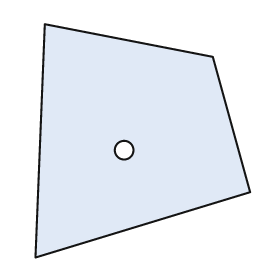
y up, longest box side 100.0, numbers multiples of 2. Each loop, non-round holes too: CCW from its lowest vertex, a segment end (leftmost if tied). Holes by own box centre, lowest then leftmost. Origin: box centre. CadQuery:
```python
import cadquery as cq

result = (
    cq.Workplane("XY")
    .moveTo(-46.0, -50.0)
    .lineTo(46.0, -22.0)
    .lineTo(30.0, 36.0)
    .lineTo(-42.0, 50.0)
    .close()
    .moveTo(-8.0, -4.0)
    .circle(4.0)
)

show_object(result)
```